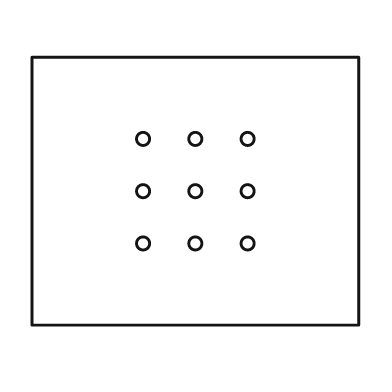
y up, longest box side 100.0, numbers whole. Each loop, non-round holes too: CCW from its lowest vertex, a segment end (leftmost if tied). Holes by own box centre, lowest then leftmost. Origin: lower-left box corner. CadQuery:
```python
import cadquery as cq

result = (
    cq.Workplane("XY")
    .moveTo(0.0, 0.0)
    .lineTo(100.0, 0.0)
    .lineTo(100.0, 82.0)
    .lineTo(0.0, 82.0)
    .close()
    .moveTo(34.0, 25.0)
    .circle(2.0)
    .moveTo(50.0, 25.0)
    .circle(2.0)
    .moveTo(66.0, 25.0)
    .circle(2.0)
    .moveTo(34.0, 41.0)
    .circle(2.0)
    .moveTo(50.0, 41.0)
    .circle(2.0)
    .moveTo(66.0, 41.0)
    .circle(2.0)
    .moveTo(34.0, 57.0)
    .circle(2.0)
    .moveTo(50.0, 57.0)
    .circle(2.0)
    .moveTo(66.0, 57.0)
    .circle(2.0)
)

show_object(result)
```